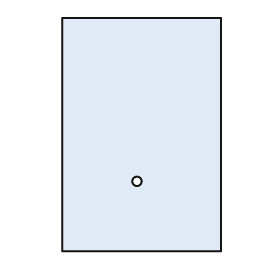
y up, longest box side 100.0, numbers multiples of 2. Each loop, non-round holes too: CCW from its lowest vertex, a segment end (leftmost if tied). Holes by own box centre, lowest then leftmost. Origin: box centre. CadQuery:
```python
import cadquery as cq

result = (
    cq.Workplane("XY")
    .moveTo(-34.0, -50.0)
    .lineTo(34.0, -50.0)
    .lineTo(34.0, 50.0)
    .lineTo(-34.0, 50.0)
    .close()
    .moveTo(-2.0, -20.0)
    .circle(2.0)
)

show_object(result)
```